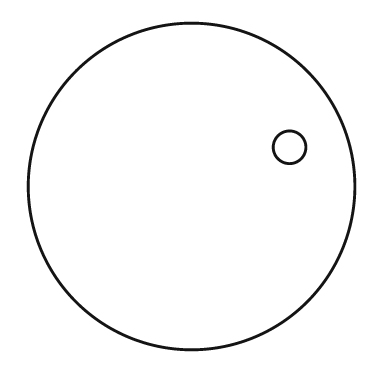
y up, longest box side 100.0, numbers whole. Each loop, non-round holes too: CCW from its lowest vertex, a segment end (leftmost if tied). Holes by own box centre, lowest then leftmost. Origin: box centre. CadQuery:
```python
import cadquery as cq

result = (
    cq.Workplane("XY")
    .moveTo(0.0, 0.0)
    .circle(50.0)
    .moveTo(30.0, 12.0)
    .circle(5.0)
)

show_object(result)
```